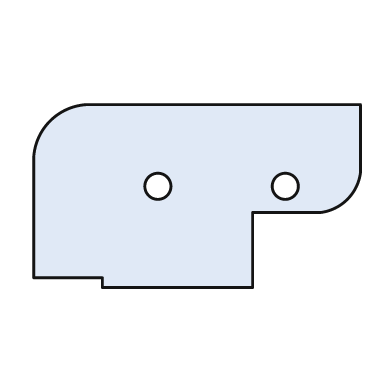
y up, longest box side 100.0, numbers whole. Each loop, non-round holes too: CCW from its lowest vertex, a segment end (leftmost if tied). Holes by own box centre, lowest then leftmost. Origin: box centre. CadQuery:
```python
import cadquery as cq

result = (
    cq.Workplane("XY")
    .moveTo(-29.0, -28.0)
    .lineTo(17.0, -28.0)
    .lineTo(17.0, -5.0)
    .lineTo(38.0, -5.0)
    .threePointArc((46.0, -1.0), (50.0, 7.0))
    .lineTo(50.0, 28.0)
    .lineTo(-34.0, 28.0)
    .threePointArc((-45.0, 23.0), (-50.0, 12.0))
    .lineTo(-50.0, -25.0)
    .lineTo(-29.0, -25.0)
    .close()
    .moveTo(-12.0, 3.0)
    .circle(4.0)
    .moveTo(27.0, 3.0)
    .circle(4.0)
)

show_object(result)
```